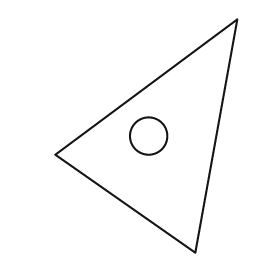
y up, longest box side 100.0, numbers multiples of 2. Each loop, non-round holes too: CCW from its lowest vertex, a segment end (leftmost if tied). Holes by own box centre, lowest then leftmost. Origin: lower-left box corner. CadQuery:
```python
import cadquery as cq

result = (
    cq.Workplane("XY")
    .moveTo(60.0, 0.0)
    .lineTo(78.0, 100.0)
    .lineTo(0.0, 42.0)
    .close()
    .moveTo(40.0, 50.0)
    .circle(8.0)
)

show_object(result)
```